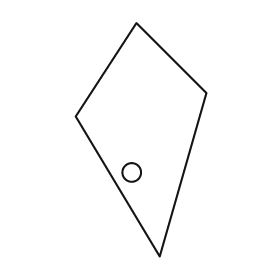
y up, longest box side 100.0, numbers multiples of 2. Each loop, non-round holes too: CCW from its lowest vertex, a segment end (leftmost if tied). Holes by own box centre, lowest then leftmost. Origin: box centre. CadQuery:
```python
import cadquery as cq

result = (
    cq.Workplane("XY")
    .moveTo(8.0, -50.0)
    .lineTo(28.0, 20.0)
    .lineTo(-2.0, 50.0)
    .lineTo(-28.0, 10.0)
    .close()
    .moveTo(-4.0, -14.0)
    .circle(4.0)
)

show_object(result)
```